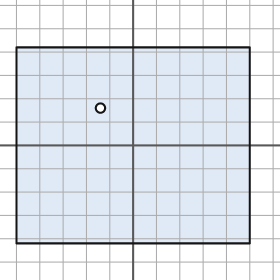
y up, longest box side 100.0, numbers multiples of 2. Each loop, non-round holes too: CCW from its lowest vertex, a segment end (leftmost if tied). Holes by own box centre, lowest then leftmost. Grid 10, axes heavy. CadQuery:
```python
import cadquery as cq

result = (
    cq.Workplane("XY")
    .moveTo(-50.0, -42.0)
    .lineTo(50.0, -42.0)
    .lineTo(50.0, 42.0)
    .lineTo(-50.0, 42.0)
    .close()
    .moveTo(-14.0, 16.0)
    .circle(2.0)
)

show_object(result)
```